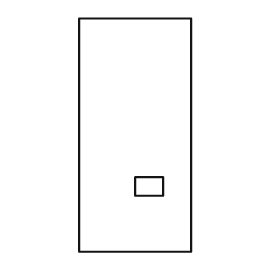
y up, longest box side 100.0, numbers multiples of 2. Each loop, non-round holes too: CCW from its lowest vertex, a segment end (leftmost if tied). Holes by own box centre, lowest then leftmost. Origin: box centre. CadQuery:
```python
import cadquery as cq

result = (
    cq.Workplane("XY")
    .moveTo(-24.0, -50.0)
    .lineTo(24.0, -50.0)
    .lineTo(24.0, 50.0)
    .lineTo(-24.0, 50.0)
    .close()
    .moveTo(0.0, -26.0)
    .lineTo(12.0, -26.0)
    .lineTo(12.0, -18.0)
    .lineTo(0.0, -18.0)
    .close()
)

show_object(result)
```